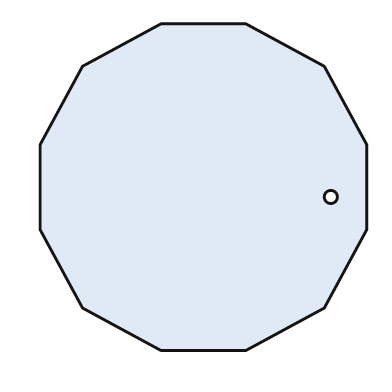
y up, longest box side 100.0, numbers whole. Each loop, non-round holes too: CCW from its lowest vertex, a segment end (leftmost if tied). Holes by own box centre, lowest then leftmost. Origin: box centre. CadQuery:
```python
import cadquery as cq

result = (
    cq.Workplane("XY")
    .moveTo(-13.0, -50.0)
    .lineTo(13.0, -50.0)
    .lineTo(37.0, -37.0)
    .lineTo(50.0, -13.0)
    .lineTo(50.0, 13.0)
    .lineTo(37.0, 37.0)
    .lineTo(13.0, 50.0)
    .lineTo(-13.0, 50.0)
    .lineTo(-37.0, 37.0)
    .lineTo(-50.0, 13.0)
    .lineTo(-50.0, -13.0)
    .lineTo(-37.0, -37.0)
    .close()
    .moveTo(39.0, -3.0)
    .circle(2.0)
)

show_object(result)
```